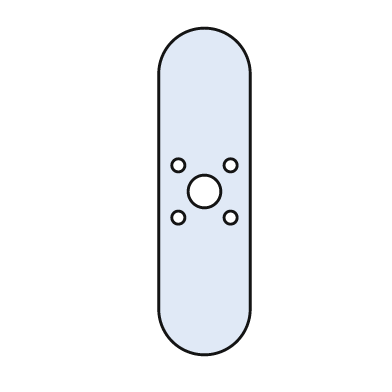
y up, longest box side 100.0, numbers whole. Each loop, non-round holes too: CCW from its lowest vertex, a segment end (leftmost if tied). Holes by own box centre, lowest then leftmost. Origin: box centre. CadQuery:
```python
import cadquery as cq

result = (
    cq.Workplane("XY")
    .moveTo(-14.0, -36.0)
    .threePointArc((0.0, -50.0), (14.0, -36.0))
    .lineTo(14.0, 36.0)
    .threePointArc((0.0, 50.0), (-14.0, 36.0))
    .close()
    .moveTo(-8.0, -8.0)
    .circle(2.0)
    .moveTo(8.0, -8.0)
    .circle(2.0)
    .moveTo(0.0, 0.0)
    .circle(5.0)
    .moveTo(-8.0, 8.0)
    .circle(2.0)
    .moveTo(8.0, 8.0)
    .circle(2.0)
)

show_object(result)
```